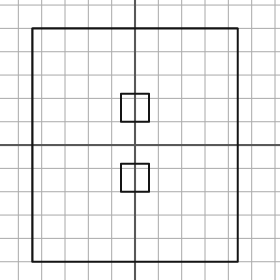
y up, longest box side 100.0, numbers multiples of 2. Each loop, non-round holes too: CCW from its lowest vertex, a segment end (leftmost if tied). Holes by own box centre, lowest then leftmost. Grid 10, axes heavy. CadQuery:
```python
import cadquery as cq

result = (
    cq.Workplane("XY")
    .moveTo(-44.0, -50.0)
    .lineTo(44.0, -50.0)
    .lineTo(44.0, 50.0)
    .lineTo(-44.0, 50.0)
    .close()
    .moveTo(-6.0, -20.0)
    .lineTo(6.0, -20.0)
    .lineTo(6.0, -8.0)
    .lineTo(-6.0, -8.0)
    .close()
    .moveTo(-6.0, 10.0)
    .lineTo(6.0, 10.0)
    .lineTo(6.0, 22.0)
    .lineTo(-6.0, 22.0)
    .close()
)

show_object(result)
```